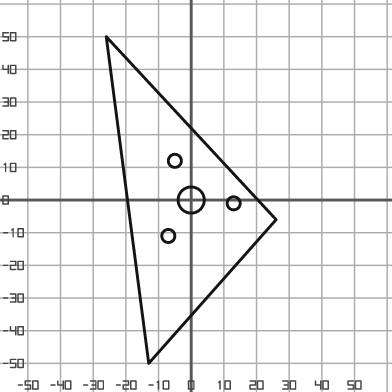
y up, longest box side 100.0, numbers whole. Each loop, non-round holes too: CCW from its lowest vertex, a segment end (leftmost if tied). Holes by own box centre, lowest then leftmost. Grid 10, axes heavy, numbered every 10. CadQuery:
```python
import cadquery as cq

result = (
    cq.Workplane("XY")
    .moveTo(-13.0, -50.0)
    .lineTo(26.0, -6.0)
    .lineTo(-26.0, 50.0)
    .close()
    .moveTo(-7.0, -11.0)
    .circle(2.0)
    .moveTo(13.0, -1.0)
    .circle(2.0)
    .moveTo(0.0, 0.0)
    .circle(4.0)
    .moveTo(-5.0, 12.0)
    .circle(2.0)
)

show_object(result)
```